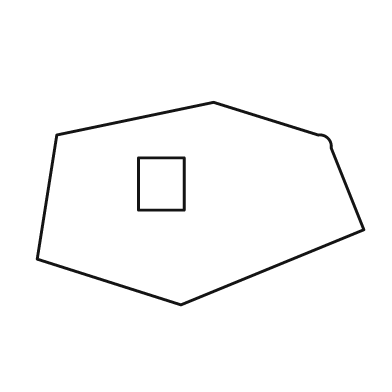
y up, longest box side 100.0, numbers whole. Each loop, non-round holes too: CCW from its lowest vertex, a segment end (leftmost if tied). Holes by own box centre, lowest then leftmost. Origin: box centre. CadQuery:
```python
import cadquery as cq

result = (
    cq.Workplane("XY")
    .moveTo(-6.0, -31.0)
    .lineTo(50.0, -8.0)
    .lineTo(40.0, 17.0)
    .threePointArc((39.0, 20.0), (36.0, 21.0))
    .lineTo(4.0, 31.0)
    .lineTo(-44.0, 21.0)
    .lineTo(-50.0, -17.0)
    .close()
    .moveTo(-19.0, -2.0)
    .lineTo(-5.0, -2.0)
    .lineTo(-5.0, 14.0)
    .lineTo(-19.0, 14.0)
    .close()
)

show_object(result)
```